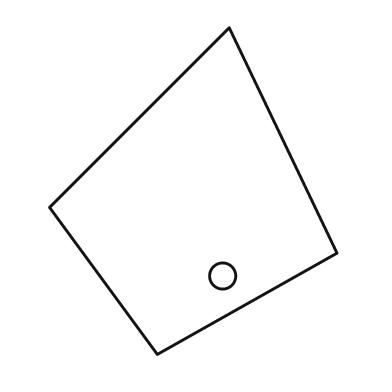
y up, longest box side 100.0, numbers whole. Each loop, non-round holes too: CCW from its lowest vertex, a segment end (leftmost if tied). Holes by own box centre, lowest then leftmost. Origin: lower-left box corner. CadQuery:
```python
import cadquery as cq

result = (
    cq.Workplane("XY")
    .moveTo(33.0, 0.0)
    .lineTo(88.0, 31.0)
    .lineTo(55.0, 100.0)
    .lineTo(0.0, 45.0)
    .close()
    .moveTo(53.0, 24.0)
    .circle(4.0)
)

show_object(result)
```